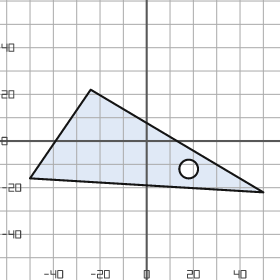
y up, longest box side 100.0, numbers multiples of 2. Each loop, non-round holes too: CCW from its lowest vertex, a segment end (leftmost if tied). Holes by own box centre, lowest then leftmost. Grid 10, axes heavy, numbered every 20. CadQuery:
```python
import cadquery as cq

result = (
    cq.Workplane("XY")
    .moveTo(50.0, -22.0)
    .lineTo(-24.0, 22.0)
    .lineTo(-50.0, -16.0)
    .close()
    .moveTo(18.0, -12.0)
    .circle(4.0)
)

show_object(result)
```